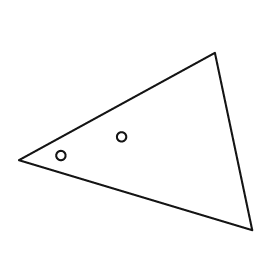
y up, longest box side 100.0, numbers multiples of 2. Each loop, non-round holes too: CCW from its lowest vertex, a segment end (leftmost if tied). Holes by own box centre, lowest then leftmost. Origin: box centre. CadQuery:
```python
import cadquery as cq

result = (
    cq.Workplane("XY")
    .moveTo(50.0, -38.0)
    .lineTo(34.0, 38.0)
    .lineTo(-50.0, -8.0)
    .close()
    .moveTo(-32.0, -6.0)
    .circle(2.0)
    .moveTo(-6.0, 2.0)
    .circle(2.0)
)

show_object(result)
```